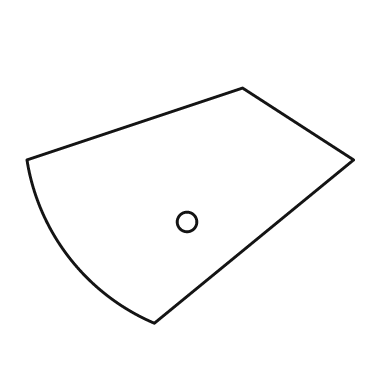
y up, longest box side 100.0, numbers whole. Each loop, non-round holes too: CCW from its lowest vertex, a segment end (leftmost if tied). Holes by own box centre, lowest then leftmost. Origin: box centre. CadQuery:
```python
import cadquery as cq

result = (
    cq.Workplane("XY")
    .moveTo(-11.0, -36.0)
    .lineTo(50.0, 14.0)
    .lineTo(16.0, 36.0)
    .lineTo(-50.0, 14.0)
    .threePointArc((-37.0, -16.0), (-11.0, -36.0))
    .close()
    .moveTo(-1.0, -5.0)
    .circle(3.0)
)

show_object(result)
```